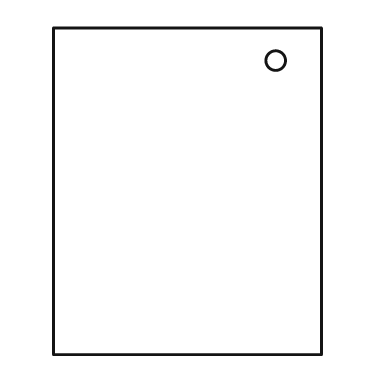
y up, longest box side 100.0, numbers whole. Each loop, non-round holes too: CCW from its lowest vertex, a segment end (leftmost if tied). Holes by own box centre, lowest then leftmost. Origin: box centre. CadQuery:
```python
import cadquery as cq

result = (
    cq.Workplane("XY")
    .moveTo(-41.0, -50.0)
    .lineTo(41.0, -50.0)
    .lineTo(41.0, 50.0)
    .lineTo(-41.0, 50.0)
    .close()
    .moveTo(27.0, 40.0)
    .circle(3.0)
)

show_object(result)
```